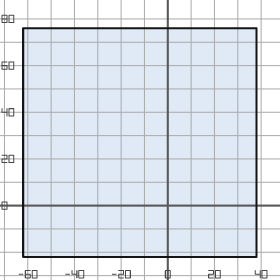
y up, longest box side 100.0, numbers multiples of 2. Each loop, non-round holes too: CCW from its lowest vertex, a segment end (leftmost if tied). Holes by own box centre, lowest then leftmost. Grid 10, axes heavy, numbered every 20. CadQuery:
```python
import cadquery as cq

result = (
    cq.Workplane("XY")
    .moveTo(-62.0, -22.0)
    .lineTo(38.0, -22.0)
    .lineTo(38.0, 76.0)
    .lineTo(-62.0, 76.0)
    .close()
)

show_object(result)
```